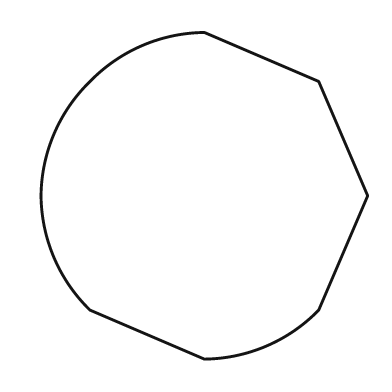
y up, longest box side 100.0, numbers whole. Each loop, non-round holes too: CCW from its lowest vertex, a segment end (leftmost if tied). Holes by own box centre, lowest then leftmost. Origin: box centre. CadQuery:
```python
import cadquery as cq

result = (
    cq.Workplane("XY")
    .moveTo(0.0, -50.0)
    .threePointArc((19.0, -46.0), (35.0, -35.0))
    .lineTo(50.0, 0.0)
    .lineTo(35.0, 35.0)
    .lineTo(0.0, 50.0)
    .threePointArc((-19.0, 46.0), (-35.0, 35.0))
    .threePointArc((-46.0, 19.0), (-50.0, 0.0))
    .threePointArc((-46.0, -19.0), (-35.0, -35.0))
    .close()
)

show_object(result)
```